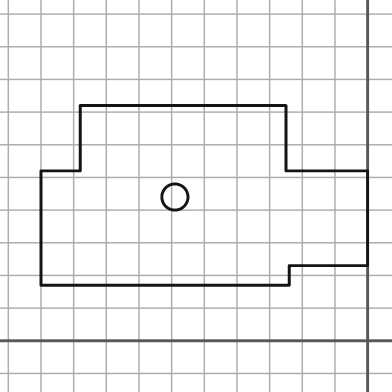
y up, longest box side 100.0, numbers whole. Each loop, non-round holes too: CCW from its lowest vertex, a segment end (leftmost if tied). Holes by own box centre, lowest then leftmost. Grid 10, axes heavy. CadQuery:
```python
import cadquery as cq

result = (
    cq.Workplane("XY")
    .moveTo(-100.0, 17.0)
    .lineTo(-24.0, 17.0)
    .lineTo(-24.0, 23.0)
    .lineTo(0.0, 23.0)
    .lineTo(0.0, 52.0)
    .lineTo(-25.0, 52.0)
    .lineTo(-25.0, 72.0)
    .lineTo(-88.0, 72.0)
    .lineTo(-88.0, 52.0)
    .lineTo(-100.0, 52.0)
    .close()
    .moveTo(-59.0, 44.0)
    .circle(4.0)
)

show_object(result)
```